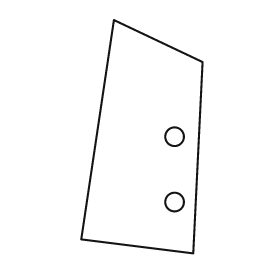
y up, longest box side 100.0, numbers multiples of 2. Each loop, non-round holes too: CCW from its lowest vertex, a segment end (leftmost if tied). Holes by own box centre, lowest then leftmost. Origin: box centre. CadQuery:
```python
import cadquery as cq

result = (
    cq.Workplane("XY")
    .moveTo(22.0, -50.0)
    .lineTo(26.0, 32.0)
    .lineTo(-12.0, 50.0)
    .lineTo(-26.0, -44.0)
    .close()
    .moveTo(14.0, -28.0)
    .circle(4.0)
    .moveTo(14.0, 0.0)
    .circle(4.0)
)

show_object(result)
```